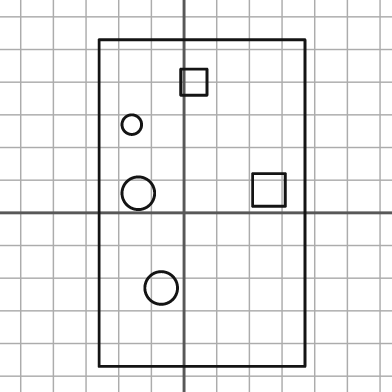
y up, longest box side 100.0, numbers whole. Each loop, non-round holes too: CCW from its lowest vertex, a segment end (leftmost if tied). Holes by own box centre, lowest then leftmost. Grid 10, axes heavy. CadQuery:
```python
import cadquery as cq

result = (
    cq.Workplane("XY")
    .moveTo(-26.0, -47.0)
    .lineTo(37.0, -47.0)
    .lineTo(37.0, 53.0)
    .lineTo(-26.0, 53.0)
    .close()
    .moveTo(-7.0, -23.0)
    .circle(5.0)
    .moveTo(-14.0, 6.0)
    .circle(5.0)
    .moveTo(21.0, 2.0)
    .lineTo(31.0, 2.0)
    .lineTo(31.0, 12.0)
    .lineTo(21.0, 12.0)
    .close()
    .moveTo(-16.0, 27.0)
    .circle(3.0)
    .moveTo(-1.0, 36.0)
    .lineTo(7.0, 36.0)
    .lineTo(7.0, 44.0)
    .lineTo(-1.0, 44.0)
    .close()
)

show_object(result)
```